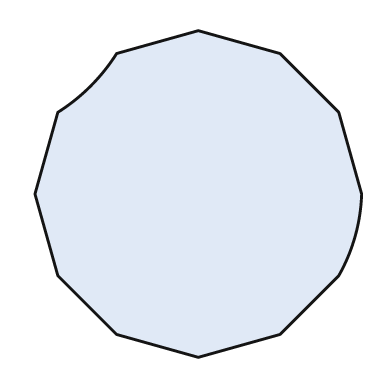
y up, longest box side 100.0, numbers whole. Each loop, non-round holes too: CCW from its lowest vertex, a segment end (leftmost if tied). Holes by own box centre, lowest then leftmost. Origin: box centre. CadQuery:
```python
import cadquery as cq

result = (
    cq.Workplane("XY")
    .moveTo(0.0, -50.0)
    .lineTo(25.0, -43.0)
    .lineTo(43.0, -25.0)
    .threePointArc((48.0, -13.0), (50.0, 0.0))
    .lineTo(43.0, 25.0)
    .lineTo(25.0, 43.0)
    .lineTo(0.0, 50.0)
    .lineTo(-25.0, 43.0)
    .threePointArc((-33.0, 33.0), (-43.0, 25.0))
    .lineTo(-50.0, 0.0)
    .lineTo(-43.0, -25.0)
    .lineTo(-25.0, -43.0)
    .close()
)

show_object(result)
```